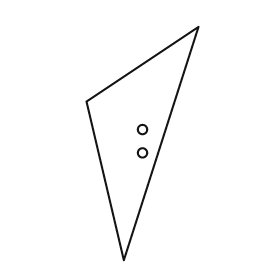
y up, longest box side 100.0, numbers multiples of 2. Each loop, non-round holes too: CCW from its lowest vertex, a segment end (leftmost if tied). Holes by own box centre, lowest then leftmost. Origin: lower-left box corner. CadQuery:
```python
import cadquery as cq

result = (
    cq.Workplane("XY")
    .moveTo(16.0, 0.0)
    .lineTo(48.0, 100.0)
    .lineTo(0.0, 68.0)
    .close()
    .moveTo(24.0, 46.0)
    .circle(2.0)
    .moveTo(24.0, 56.0)
    .circle(2.0)
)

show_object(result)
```